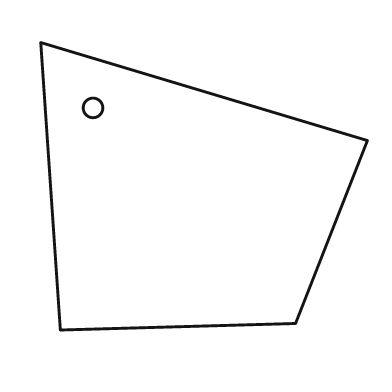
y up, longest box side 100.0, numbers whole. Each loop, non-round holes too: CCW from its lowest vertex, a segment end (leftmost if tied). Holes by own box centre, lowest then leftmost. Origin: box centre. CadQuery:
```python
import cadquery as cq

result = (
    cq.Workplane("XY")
    .moveTo(-44.0, -44.0)
    .lineTo(28.0, -42.0)
    .lineTo(50.0, 14.0)
    .lineTo(-50.0, 44.0)
    .close()
    .moveTo(-34.0, 24.0)
    .circle(3.0)
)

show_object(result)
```